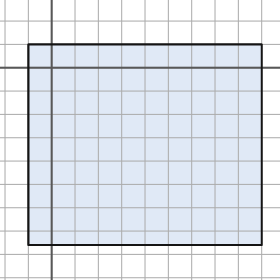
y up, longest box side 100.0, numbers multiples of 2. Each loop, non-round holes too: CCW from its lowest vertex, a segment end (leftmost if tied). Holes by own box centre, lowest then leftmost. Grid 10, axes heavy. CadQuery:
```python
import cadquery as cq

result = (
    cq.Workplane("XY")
    .moveTo(-10.0, -76.0)
    .lineTo(90.0, -76.0)
    .lineTo(90.0, 10.0)
    .lineTo(-10.0, 10.0)
    .close()
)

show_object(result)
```